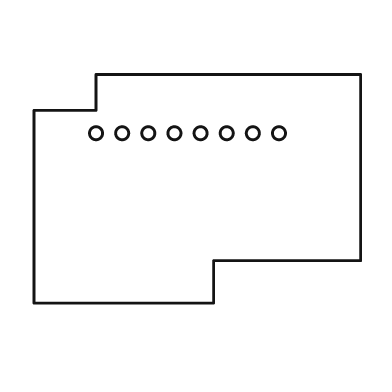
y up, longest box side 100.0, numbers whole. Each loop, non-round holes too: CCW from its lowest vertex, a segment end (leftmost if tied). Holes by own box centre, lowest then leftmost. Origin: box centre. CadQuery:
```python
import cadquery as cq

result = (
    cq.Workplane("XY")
    .moveTo(-50.0, -35.0)
    .lineTo(5.0, -35.0)
    .lineTo(5.0, -22.0)
    .lineTo(50.0, -22.0)
    .lineTo(50.0, 35.0)
    .lineTo(-31.0, 35.0)
    .lineTo(-31.0, 24.0)
    .lineTo(-50.0, 24.0)
    .close()
    .moveTo(-31.0, 17.0)
    .circle(2.0)
    .moveTo(-23.0, 17.0)
    .circle(2.0)
    .moveTo(-15.0, 17.0)
    .circle(2.0)
    .moveTo(-7.0, 17.0)
    .circle(2.0)
    .moveTo(1.0, 17.0)
    .circle(2.0)
    .moveTo(9.0, 17.0)
    .circle(2.0)
    .moveTo(17.0, 17.0)
    .circle(2.0)
    .moveTo(25.0, 17.0)
    .circle(2.0)
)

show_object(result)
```